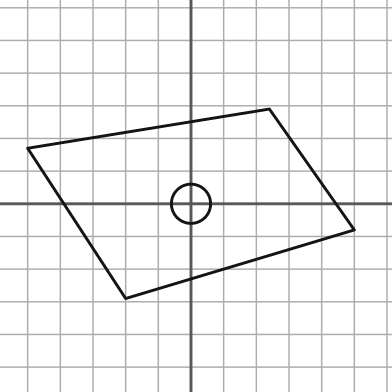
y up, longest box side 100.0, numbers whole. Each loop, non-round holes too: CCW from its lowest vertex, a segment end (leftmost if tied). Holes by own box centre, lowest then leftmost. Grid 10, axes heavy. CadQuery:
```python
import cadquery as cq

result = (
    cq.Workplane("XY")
    .moveTo(-20.0, -29.0)
    .lineTo(50.0, -8.0)
    .lineTo(24.0, 29.0)
    .lineTo(-50.0, 17.0)
    .close()
    .moveTo(0.0, 0.0)
    .circle(6.0)
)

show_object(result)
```